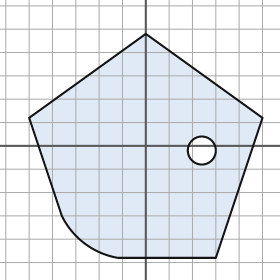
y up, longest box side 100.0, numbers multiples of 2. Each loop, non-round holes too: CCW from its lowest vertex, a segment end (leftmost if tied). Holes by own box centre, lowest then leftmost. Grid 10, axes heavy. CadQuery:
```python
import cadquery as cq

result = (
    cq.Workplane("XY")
    .moveTo(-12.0, -48.0)
    .lineTo(30.0, -48.0)
    .lineTo(50.0, 12.0)
    .lineTo(0.0, 48.0)
    .lineTo(-50.0, 12.0)
    .lineTo(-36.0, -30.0)
    .threePointArc((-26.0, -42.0), (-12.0, -48.0))
    .close()
    .moveTo(24.0, -2.0)
    .circle(6.0)
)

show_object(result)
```